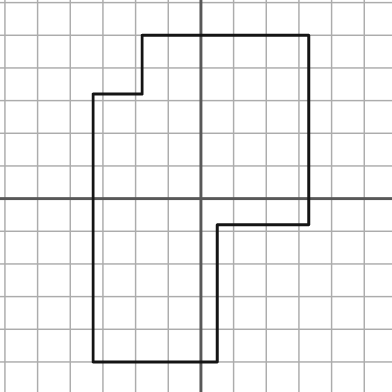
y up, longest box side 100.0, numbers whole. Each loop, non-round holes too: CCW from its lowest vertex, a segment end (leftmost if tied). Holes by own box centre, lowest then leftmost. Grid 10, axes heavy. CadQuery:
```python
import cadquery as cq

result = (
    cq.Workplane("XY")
    .moveTo(-33.0, -50.0)
    .lineTo(5.0, -50.0)
    .lineTo(5.0, -8.0)
    .lineTo(33.0, -8.0)
    .lineTo(33.0, 50.0)
    .lineTo(-18.0, 50.0)
    .lineTo(-18.0, 32.0)
    .lineTo(-33.0, 32.0)
    .close()
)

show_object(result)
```